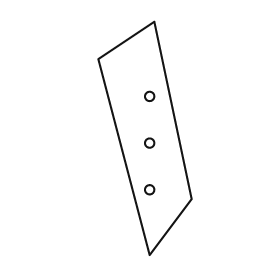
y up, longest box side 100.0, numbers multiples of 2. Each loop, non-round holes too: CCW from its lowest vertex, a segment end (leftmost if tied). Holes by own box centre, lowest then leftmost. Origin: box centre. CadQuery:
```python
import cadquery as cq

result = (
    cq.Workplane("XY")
    .moveTo(2.0, -50.0)
    .lineTo(20.0, -26.0)
    .lineTo(4.0, 50.0)
    .lineTo(-20.0, 34.0)
    .close()
    .moveTo(2.0, -22.0)
    .circle(2.0)
    .moveTo(2.0, -2.0)
    .circle(2.0)
    .moveTo(2.0, 18.0)
    .circle(2.0)
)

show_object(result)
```